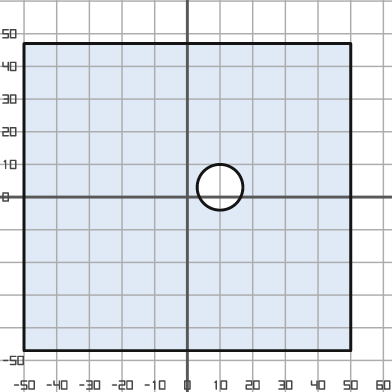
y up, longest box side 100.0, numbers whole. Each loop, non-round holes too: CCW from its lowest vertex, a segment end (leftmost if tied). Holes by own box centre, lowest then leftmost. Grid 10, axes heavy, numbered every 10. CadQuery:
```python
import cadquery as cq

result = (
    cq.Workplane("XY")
    .moveTo(-50.0, -47.0)
    .lineTo(50.0, -47.0)
    .lineTo(50.0, 47.0)
    .lineTo(-50.0, 47.0)
    .close()
    .moveTo(10.0, 3.0)
    .circle(7.0)
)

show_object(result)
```